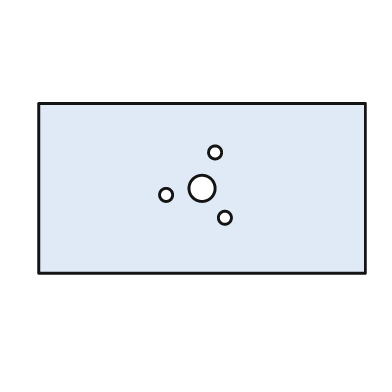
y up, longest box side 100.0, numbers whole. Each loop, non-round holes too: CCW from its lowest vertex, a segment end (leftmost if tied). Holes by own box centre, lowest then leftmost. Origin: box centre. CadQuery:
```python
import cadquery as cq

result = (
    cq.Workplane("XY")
    .moveTo(-50.0, -26.0)
    .lineTo(50.0, -26.0)
    .lineTo(50.0, 26.0)
    .lineTo(-50.0, 26.0)
    .close()
    .moveTo(7.0, -9.0)
    .circle(2.0)
    .moveTo(-11.0, -2.0)
    .circle(2.0)
    .moveTo(0.0, 0.0)
    .circle(4.0)
    .moveTo(4.0, 11.0)
    .circle(2.0)
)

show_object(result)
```